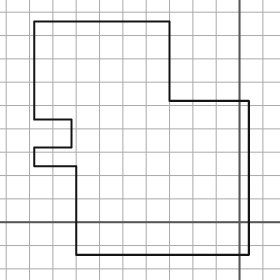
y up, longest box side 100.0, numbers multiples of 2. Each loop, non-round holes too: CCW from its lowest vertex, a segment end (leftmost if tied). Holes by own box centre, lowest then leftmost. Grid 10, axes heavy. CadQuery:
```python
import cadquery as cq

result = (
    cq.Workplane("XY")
    .moveTo(-70.0, -14.0)
    .lineTo(4.0, -14.0)
    .lineTo(4.0, 52.0)
    .lineTo(-30.0, 52.0)
    .lineTo(-30.0, 86.0)
    .lineTo(-88.0, 86.0)
    .lineTo(-88.0, 44.0)
    .lineTo(-72.0, 44.0)
    .lineTo(-72.0, 32.0)
    .lineTo(-88.0, 32.0)
    .lineTo(-88.0, 24.0)
    .lineTo(-70.0, 24.0)
    .close()
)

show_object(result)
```